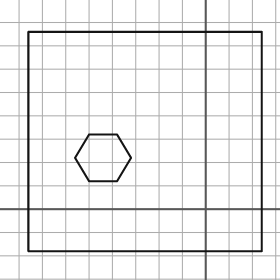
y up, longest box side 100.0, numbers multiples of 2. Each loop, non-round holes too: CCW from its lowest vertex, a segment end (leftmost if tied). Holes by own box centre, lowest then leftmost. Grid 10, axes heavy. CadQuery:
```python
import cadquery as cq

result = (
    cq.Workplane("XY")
    .moveTo(-76.0, -18.0)
    .lineTo(24.0, -18.0)
    .lineTo(24.0, 76.0)
    .lineTo(-76.0, 76.0)
    .close()
    .moveTo(-50.0, 12.0)
    .lineTo(-38.0, 12.0)
    .lineTo(-32.0, 22.0)
    .lineTo(-38.0, 32.0)
    .lineTo(-50.0, 32.0)
    .lineTo(-56.0, 22.0)
    .close()
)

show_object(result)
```